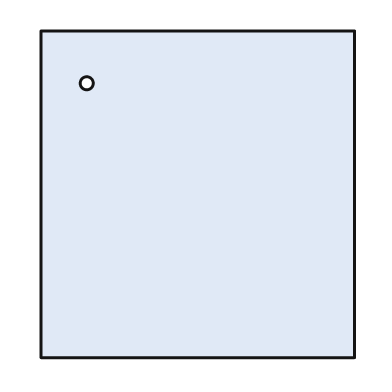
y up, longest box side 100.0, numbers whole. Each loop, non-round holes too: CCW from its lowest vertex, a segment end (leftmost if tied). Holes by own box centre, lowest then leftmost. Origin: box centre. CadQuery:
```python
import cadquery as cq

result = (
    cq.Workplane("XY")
    .moveTo(-48.0, -50.0)
    .lineTo(48.0, -50.0)
    .lineTo(48.0, 50.0)
    .lineTo(-48.0, 50.0)
    .close()
    .moveTo(-34.0, 34.0)
    .circle(2.0)
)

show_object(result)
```